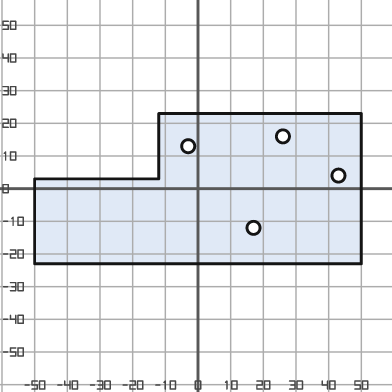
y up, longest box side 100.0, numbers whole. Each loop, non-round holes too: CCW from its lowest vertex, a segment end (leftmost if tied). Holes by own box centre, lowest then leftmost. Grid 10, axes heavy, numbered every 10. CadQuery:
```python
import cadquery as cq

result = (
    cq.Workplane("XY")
    .moveTo(-50.0, -23.0)
    .lineTo(50.0, -23.0)
    .lineTo(50.0, 23.0)
    .lineTo(-12.0, 23.0)
    .lineTo(-12.0, 3.0)
    .lineTo(-50.0, 3.0)
    .close()
    .moveTo(17.0, -12.0)
    .circle(2.0)
    .moveTo(43.0, 4.0)
    .circle(2.0)
    .moveTo(-3.0, 13.0)
    .circle(2.0)
    .moveTo(26.0, 16.0)
    .circle(2.0)
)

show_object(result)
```